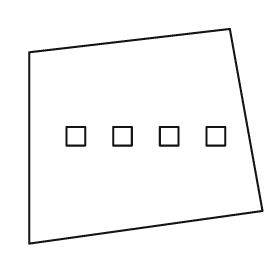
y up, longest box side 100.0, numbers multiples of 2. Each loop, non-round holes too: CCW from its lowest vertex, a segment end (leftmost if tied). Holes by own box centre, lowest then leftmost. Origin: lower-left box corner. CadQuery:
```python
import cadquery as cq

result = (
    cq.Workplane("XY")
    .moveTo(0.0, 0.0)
    .lineTo(100.0, 14.0)
    .lineTo(86.0, 92.0)
    .lineTo(0.0, 82.0)
    .close()
    .moveTo(16.0, 42.0)
    .lineTo(24.0, 42.0)
    .lineTo(24.0, 50.0)
    .lineTo(16.0, 50.0)
    .close()
    .moveTo(36.0, 42.0)
    .lineTo(44.0, 42.0)
    .lineTo(44.0, 50.0)
    .lineTo(36.0, 50.0)
    .close()
    .moveTo(56.0, 42.0)
    .lineTo(64.0, 42.0)
    .lineTo(64.0, 50.0)
    .lineTo(56.0, 50.0)
    .close()
    .moveTo(76.0, 42.0)
    .lineTo(84.0, 42.0)
    .lineTo(84.0, 50.0)
    .lineTo(76.0, 50.0)
    .close()
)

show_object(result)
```